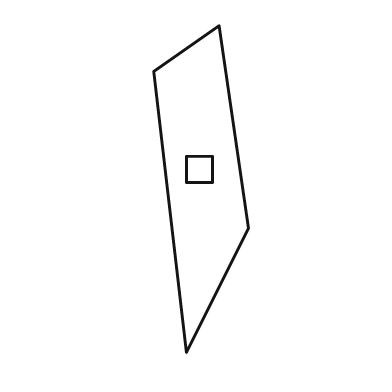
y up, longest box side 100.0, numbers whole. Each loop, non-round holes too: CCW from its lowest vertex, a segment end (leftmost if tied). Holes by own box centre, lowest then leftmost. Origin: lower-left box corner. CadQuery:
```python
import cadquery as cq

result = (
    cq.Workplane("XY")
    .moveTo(10.0, 0.0)
    .lineTo(29.0, 38.0)
    .lineTo(20.0, 100.0)
    .lineTo(0.0, 86.0)
    .close()
    .moveTo(10.0, 52.0)
    .lineTo(18.0, 52.0)
    .lineTo(18.0, 60.0)
    .lineTo(10.0, 60.0)
    .close()
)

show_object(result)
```